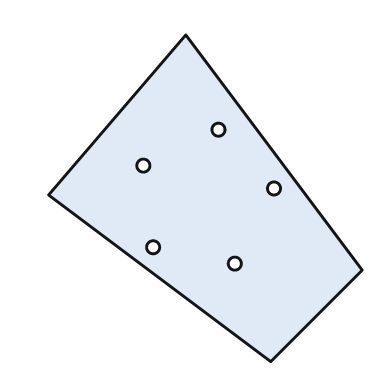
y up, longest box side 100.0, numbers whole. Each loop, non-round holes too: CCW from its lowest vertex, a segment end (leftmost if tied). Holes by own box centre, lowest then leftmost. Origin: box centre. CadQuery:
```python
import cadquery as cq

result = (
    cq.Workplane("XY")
    .moveTo(20.0, -50.0)
    .lineTo(48.0, -22.0)
    .lineTo(-6.0, 50.0)
    .lineTo(-48.0, 1.0)
    .close()
    .moveTo(9.0, -20.0)
    .circle(2.0)
    .moveTo(-16.0, -15.0)
    .circle(2.0)
    .moveTo(21.0, 3.0)
    .circle(2.0)
    .moveTo(-19.0, 10.0)
    .circle(2.0)
    .moveTo(4.0, 21.0)
    .circle(2.0)
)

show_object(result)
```